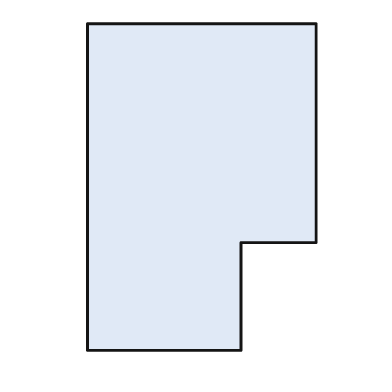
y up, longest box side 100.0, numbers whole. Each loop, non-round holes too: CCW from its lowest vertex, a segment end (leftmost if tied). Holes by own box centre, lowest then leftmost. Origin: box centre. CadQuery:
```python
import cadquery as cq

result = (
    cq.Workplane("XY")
    .moveTo(-35.0, -50.0)
    .lineTo(12.0, -50.0)
    .lineTo(12.0, -17.0)
    .lineTo(35.0, -17.0)
    .lineTo(35.0, 50.0)
    .lineTo(-35.0, 50.0)
    .close()
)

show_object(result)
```